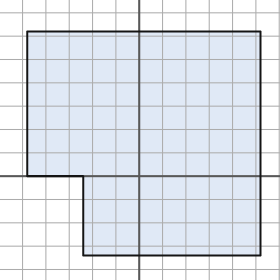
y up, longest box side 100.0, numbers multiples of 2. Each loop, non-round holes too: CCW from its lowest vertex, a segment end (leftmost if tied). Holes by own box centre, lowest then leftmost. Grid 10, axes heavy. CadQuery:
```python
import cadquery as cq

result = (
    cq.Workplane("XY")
    .moveTo(-24.0, -34.0)
    .lineTo(52.0, -34.0)
    .lineTo(52.0, 62.0)
    .lineTo(-48.0, 62.0)
    .lineTo(-48.0, 0.0)
    .lineTo(-24.0, 0.0)
    .close()
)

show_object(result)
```